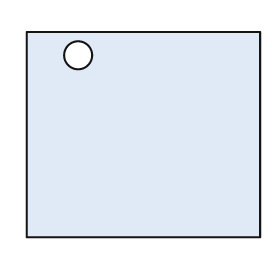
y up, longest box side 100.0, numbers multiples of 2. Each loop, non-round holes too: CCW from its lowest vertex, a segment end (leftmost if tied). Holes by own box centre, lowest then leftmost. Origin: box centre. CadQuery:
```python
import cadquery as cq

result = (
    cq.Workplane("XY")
    .moveTo(-50.0, -44.0)
    .lineTo(50.0, -44.0)
    .lineTo(50.0, 44.0)
    .lineTo(-50.0, 44.0)
    .close()
    .moveTo(-28.0, 34.0)
    .circle(6.0)
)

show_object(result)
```